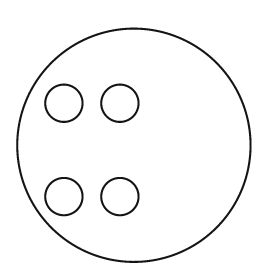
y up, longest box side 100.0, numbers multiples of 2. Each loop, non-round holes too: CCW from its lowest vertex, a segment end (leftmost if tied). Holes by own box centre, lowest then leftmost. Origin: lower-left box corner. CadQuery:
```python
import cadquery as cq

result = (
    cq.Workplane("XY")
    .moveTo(50.0, 50.0)
    .circle(50.0)
    .moveTo(20.0, 28.0)
    .circle(8.0)
    .moveTo(44.0, 28.0)
    .circle(8.0)
    .moveTo(20.0, 68.0)
    .circle(8.0)
    .moveTo(44.0, 68.0)
    .circle(8.0)
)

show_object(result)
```